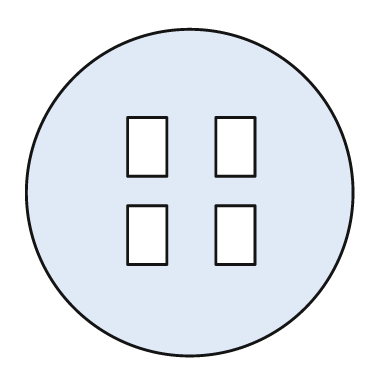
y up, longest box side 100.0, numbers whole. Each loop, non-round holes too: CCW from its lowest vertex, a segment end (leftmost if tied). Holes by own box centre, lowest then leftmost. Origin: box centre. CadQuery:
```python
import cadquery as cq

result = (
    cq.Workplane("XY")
    .moveTo(0.0, 0.0)
    .circle(50.0)
    .moveTo(-19.0, -22.0)
    .lineTo(-7.0, -22.0)
    .lineTo(-7.0, -4.0)
    .lineTo(-19.0, -4.0)
    .close()
    .moveTo(8.0, -22.0)
    .lineTo(20.0, -22.0)
    .lineTo(20.0, -4.0)
    .lineTo(8.0, -4.0)
    .close()
    .moveTo(-19.0, 5.0)
    .lineTo(-7.0, 5.0)
    .lineTo(-7.0, 23.0)
    .lineTo(-19.0, 23.0)
    .close()
    .moveTo(8.0, 5.0)
    .lineTo(20.0, 5.0)
    .lineTo(20.0, 23.0)
    .lineTo(8.0, 23.0)
    .close()
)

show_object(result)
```